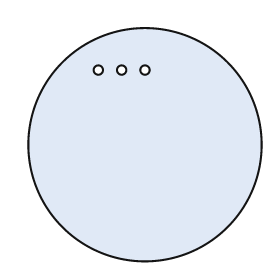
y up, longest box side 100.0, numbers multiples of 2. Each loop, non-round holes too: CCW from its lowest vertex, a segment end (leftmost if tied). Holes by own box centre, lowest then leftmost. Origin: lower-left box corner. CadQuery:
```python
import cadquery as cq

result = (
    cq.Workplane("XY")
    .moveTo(50.0, 50.0)
    .circle(50.0)
    .moveTo(30.0, 82.0)
    .circle(2.0)
    .moveTo(40.0, 82.0)
    .circle(2.0)
    .moveTo(50.0, 82.0)
    .circle(2.0)
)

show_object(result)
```